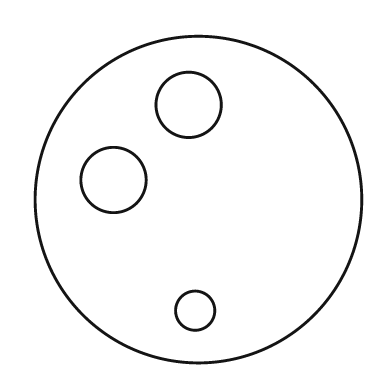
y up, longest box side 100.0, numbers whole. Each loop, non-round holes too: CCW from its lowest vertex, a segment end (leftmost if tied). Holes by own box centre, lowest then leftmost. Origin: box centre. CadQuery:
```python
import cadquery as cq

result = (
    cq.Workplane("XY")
    .moveTo(0.0, 0.0)
    .circle(50.0)
    .moveTo(-1.0, -34.0)
    .circle(6.0)
    .moveTo(-26.0, 6.0)
    .circle(10.0)
    .moveTo(-3.0, 29.0)
    .circle(10.0)
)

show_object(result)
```